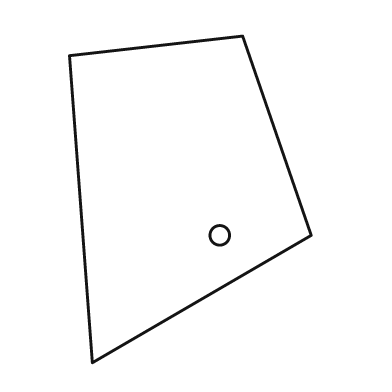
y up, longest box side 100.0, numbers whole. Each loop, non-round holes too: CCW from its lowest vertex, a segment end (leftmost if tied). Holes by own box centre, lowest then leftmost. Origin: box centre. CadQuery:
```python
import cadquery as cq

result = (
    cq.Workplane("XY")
    .moveTo(-30.0, -50.0)
    .lineTo(37.0, -11.0)
    .lineTo(16.0, 50.0)
    .lineTo(-37.0, 44.0)
    .close()
    .moveTo(9.0, -11.0)
    .circle(3.0)
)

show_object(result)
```